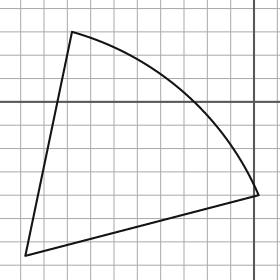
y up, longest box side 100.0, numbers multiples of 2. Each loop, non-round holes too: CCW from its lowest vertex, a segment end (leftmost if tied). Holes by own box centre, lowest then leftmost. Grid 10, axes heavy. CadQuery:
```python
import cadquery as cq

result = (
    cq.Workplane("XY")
    .moveTo(-98.0, -66.0)
    .lineTo(2.0, -40.0)
    .threePointArc((-30.0, 4.0), (-78.0, 30.0))
    .close()
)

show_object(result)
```